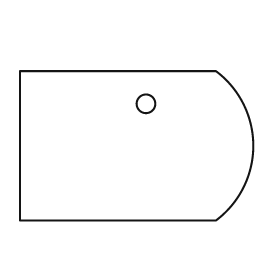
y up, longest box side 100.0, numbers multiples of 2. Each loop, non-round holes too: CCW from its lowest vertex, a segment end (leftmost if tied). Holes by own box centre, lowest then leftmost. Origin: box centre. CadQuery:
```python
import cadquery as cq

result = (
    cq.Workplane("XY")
    .moveTo(-50.0, -32.0)
    .lineTo(34.0, -32.0)
    .threePointArc((50.0, 0.0), (34.0, 32.0))
    .lineTo(-50.0, 32.0)
    .close()
    .moveTo(4.0, 18.0)
    .circle(4.0)
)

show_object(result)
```